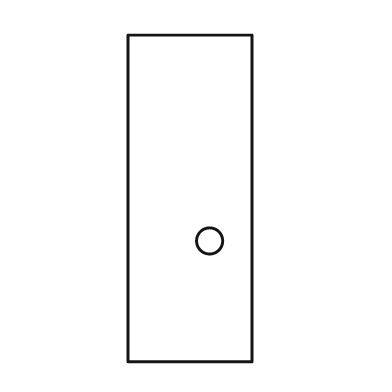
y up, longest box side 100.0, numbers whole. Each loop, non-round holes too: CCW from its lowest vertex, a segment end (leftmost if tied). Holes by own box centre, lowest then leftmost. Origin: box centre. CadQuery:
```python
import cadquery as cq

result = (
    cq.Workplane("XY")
    .moveTo(-19.0, -50.0)
    .lineTo(19.0, -50.0)
    .lineTo(19.0, 50.0)
    .lineTo(-19.0, 50.0)
    .close()
    .moveTo(6.0, -13.0)
    .circle(4.0)
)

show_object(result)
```